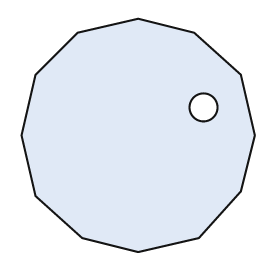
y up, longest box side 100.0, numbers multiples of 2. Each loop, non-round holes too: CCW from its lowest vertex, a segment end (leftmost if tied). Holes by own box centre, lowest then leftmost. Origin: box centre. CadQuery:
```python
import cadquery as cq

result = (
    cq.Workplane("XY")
    .moveTo(0.0, -50.0)
    .lineTo(26.0, -44.0)
    .lineTo(44.0, -24.0)
    .lineTo(50.0, 0.0)
    .lineTo(44.0, 26.0)
    .lineTo(24.0, 44.0)
    .lineTo(0.0, 50.0)
    .lineTo(-26.0, 44.0)
    .lineTo(-44.0, 26.0)
    .lineTo(-50.0, 0.0)
    .lineTo(-44.0, -26.0)
    .lineTo(-24.0, -44.0)
    .close()
    .moveTo(28.0, 12.0)
    .circle(6.0)
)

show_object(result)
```